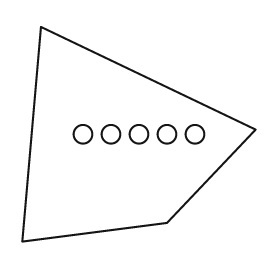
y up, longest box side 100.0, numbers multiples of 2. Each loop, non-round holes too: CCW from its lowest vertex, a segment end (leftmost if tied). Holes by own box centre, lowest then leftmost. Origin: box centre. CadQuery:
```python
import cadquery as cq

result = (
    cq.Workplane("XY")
    .moveTo(-50.0, -46.0)
    .lineTo(12.0, -38.0)
    .lineTo(50.0, 2.0)
    .lineTo(-42.0, 46.0)
    .close()
    .moveTo(-24.0, 0.0)
    .circle(4.0)
    .moveTo(-12.0, 0.0)
    .circle(4.0)
    .moveTo(0.0, 0.0)
    .circle(4.0)
    .moveTo(12.0, 0.0)
    .circle(4.0)
    .moveTo(24.0, 0.0)
    .circle(4.0)
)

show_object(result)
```